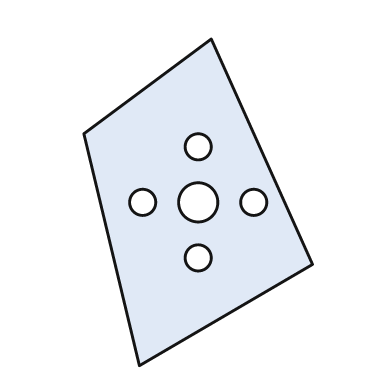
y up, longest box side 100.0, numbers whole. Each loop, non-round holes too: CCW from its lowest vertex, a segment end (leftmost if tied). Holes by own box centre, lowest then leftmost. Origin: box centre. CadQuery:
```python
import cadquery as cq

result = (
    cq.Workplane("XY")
    .moveTo(-18.0, -50.0)
    .lineTo(35.0, -19.0)
    .lineTo(4.0, 50.0)
    .lineTo(-35.0, 21.0)
    .close()
    .moveTo(0.0, -17.0)
    .circle(4.0)
    .moveTo(-17.0, 0.0)
    .circle(4.0)
    .moveTo(0.0, 0.0)
    .circle(6.0)
    .moveTo(17.0, 0.0)
    .circle(4.0)
    .moveTo(0.0, 17.0)
    .circle(4.0)
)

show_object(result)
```